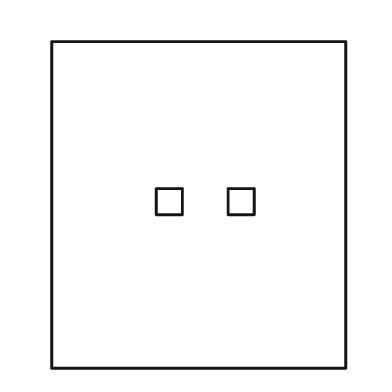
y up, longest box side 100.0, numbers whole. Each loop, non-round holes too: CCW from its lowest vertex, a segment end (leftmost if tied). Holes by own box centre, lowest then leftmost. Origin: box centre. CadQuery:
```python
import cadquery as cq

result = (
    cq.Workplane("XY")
    .moveTo(-45.0, -50.0)
    .lineTo(45.0, -50.0)
    .lineTo(45.0, 50.0)
    .lineTo(-45.0, 50.0)
    .close()
    .moveTo(-13.0, -3.0)
    .lineTo(-5.0, -3.0)
    .lineTo(-5.0, 5.0)
    .lineTo(-13.0, 5.0)
    .close()
    .moveTo(9.0, -3.0)
    .lineTo(17.0, -3.0)
    .lineTo(17.0, 5.0)
    .lineTo(9.0, 5.0)
    .close()
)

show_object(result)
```